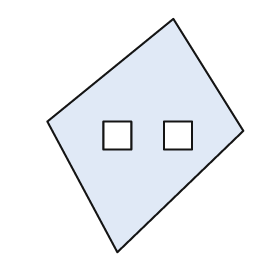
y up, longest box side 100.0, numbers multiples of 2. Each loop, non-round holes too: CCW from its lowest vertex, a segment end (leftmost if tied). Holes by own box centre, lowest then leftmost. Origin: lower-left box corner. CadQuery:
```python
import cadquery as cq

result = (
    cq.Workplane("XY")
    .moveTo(30.0, 0.0)
    .lineTo(84.0, 52.0)
    .lineTo(54.0, 100.0)
    .lineTo(0.0, 56.0)
    .close()
    .moveTo(24.0, 44.0)
    .lineTo(36.0, 44.0)
    .lineTo(36.0, 56.0)
    .lineTo(24.0, 56.0)
    .close()
    .moveTo(50.0, 44.0)
    .lineTo(62.0, 44.0)
    .lineTo(62.0, 56.0)
    .lineTo(50.0, 56.0)
    .close()
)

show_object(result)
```